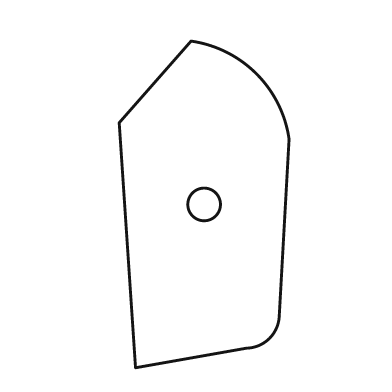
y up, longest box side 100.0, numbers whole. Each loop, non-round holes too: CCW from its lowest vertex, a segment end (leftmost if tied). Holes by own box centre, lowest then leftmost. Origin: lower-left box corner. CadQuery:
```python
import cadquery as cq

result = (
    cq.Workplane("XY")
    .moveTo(5.0, 0.0)
    .lineTo(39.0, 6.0)
    .threePointArc((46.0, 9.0), (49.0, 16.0))
    .lineTo(52.0, 70.0)
    .threePointArc((42.0, 90.0), (22.0, 100.0))
    .lineTo(0.0, 75.0)
    .close()
    .moveTo(26.0, 50.0)
    .circle(5.0)
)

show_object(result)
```